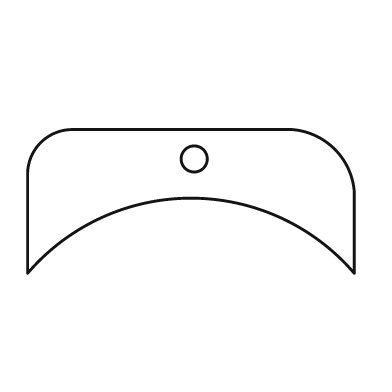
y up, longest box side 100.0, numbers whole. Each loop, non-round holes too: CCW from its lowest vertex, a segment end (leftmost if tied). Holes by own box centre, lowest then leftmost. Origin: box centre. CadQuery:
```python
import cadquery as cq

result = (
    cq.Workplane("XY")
    .moveTo(-50.0, -22.0)
    .threePointArc((0.0, 1.0), (50.0, -22.0))
    .lineTo(50.0, 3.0)
    .threePointArc((44.0, 16.0), (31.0, 22.0))
    .lineTo(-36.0, 22.0)
    .threePointArc((-46.0, 18.0), (-50.0, 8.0))
    .close()
    .moveTo(1.0, 13.0)
    .circle(4.0)
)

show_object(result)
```